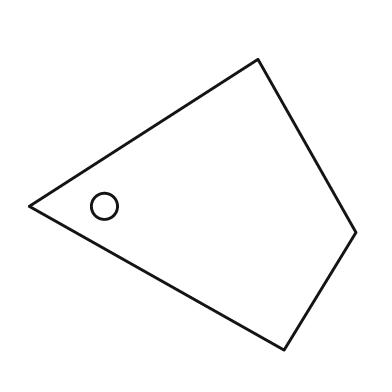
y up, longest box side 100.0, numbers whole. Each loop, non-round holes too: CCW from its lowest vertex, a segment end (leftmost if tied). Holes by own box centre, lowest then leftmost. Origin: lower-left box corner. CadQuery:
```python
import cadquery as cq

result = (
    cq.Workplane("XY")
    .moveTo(78.0, 0.0)
    .lineTo(100.0, 36.0)
    .lineTo(70.0, 89.0)
    .lineTo(0.0, 44.0)
    .close()
    .moveTo(23.0, 44.0)
    .circle(4.0)
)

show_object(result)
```